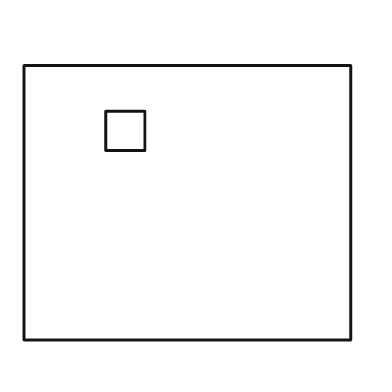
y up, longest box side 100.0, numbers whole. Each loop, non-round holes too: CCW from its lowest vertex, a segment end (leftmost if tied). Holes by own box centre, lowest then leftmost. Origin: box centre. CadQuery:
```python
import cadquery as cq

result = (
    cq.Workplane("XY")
    .moveTo(-50.0, -42.0)
    .lineTo(50.0, -42.0)
    .lineTo(50.0, 42.0)
    .lineTo(-50.0, 42.0)
    .close()
    .moveTo(-25.0, 16.0)
    .lineTo(-13.0, 16.0)
    .lineTo(-13.0, 28.0)
    .lineTo(-25.0, 28.0)
    .close()
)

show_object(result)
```